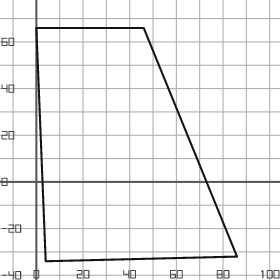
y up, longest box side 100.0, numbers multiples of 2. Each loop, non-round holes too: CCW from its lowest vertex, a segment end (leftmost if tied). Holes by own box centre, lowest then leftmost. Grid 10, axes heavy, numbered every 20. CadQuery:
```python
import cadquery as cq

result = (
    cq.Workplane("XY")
    .moveTo(4.0, -34.0)
    .lineTo(86.0, -32.0)
    .lineTo(46.0, 66.0)
    .lineTo(0.0, 66.0)
    .close()
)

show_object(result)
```